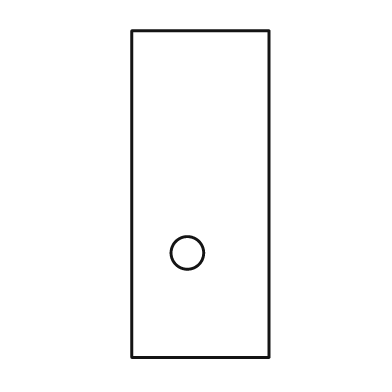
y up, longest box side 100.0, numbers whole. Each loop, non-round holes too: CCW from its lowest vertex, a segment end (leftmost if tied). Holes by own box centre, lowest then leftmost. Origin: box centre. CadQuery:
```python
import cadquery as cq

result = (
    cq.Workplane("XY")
    .moveTo(-21.0, -50.0)
    .lineTo(21.0, -50.0)
    .lineTo(21.0, 50.0)
    .lineTo(-21.0, 50.0)
    .close()
    .moveTo(-4.0, -18.0)
    .circle(5.0)
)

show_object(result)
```